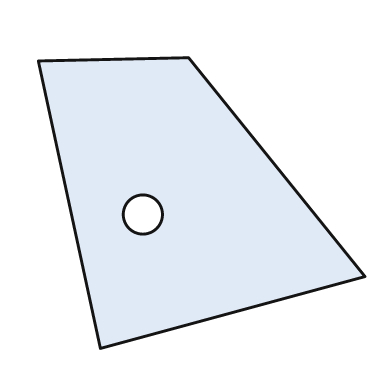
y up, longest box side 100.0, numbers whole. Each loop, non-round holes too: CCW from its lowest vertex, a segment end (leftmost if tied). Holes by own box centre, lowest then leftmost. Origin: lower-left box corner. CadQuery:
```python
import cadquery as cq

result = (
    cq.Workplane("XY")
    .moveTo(19.0, 0.0)
    .lineTo(100.0, 22.0)
    .lineTo(46.0, 89.0)
    .lineTo(0.0, 88.0)
    .close()
    .moveTo(32.0, 41.0)
    .circle(6.0)
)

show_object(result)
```